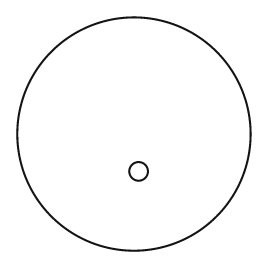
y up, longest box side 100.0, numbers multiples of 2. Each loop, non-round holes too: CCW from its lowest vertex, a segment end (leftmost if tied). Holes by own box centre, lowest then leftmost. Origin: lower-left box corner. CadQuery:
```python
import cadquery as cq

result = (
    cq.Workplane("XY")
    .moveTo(50.0, 50.0)
    .circle(50.0)
    .moveTo(52.0, 34.0)
    .circle(4.0)
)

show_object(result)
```